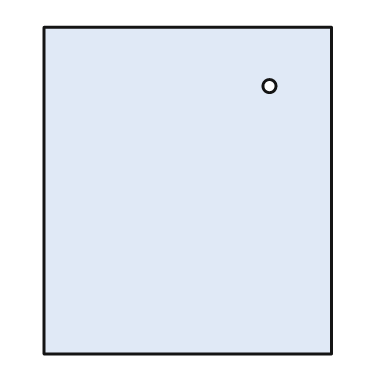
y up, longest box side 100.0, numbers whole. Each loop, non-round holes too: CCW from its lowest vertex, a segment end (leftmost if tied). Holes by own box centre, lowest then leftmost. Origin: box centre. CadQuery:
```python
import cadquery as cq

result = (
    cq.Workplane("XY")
    .moveTo(-44.0, -50.0)
    .lineTo(44.0, -50.0)
    .lineTo(44.0, 50.0)
    .lineTo(-44.0, 50.0)
    .close()
    .moveTo(25.0, 32.0)
    .circle(2.0)
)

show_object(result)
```